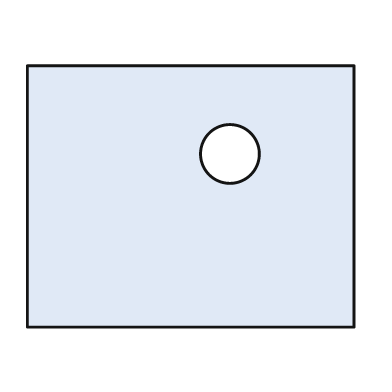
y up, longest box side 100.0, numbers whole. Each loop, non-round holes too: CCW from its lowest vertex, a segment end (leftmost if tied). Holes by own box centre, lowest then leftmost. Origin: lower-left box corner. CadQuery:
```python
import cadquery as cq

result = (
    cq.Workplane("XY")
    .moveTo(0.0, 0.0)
    .lineTo(100.0, 0.0)
    .lineTo(100.0, 80.0)
    .lineTo(0.0, 80.0)
    .close()
    .moveTo(62.0, 53.0)
    .circle(9.0)
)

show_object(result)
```